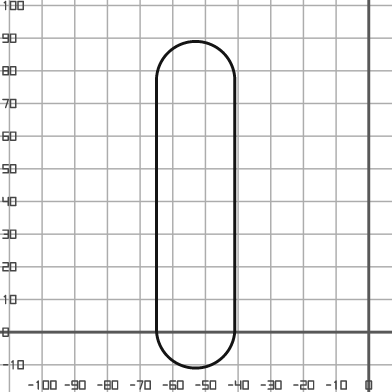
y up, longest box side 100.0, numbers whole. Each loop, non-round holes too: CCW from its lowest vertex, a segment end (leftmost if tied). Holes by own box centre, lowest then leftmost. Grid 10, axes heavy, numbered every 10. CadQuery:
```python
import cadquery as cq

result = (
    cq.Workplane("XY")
    .moveTo(-65.0, 1.0)
    .threePointArc((-53.0, -11.0), (-41.0, 1.0))
    .lineTo(-41.0, 77.0)
    .threePointArc((-53.0, 89.0), (-65.0, 77.0))
    .close()
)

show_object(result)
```